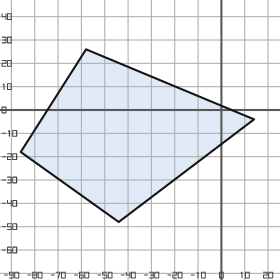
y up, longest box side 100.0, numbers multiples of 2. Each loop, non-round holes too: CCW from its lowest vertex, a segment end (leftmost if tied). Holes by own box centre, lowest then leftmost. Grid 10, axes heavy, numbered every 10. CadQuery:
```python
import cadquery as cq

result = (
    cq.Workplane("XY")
    .moveTo(-44.0, -48.0)
    .lineTo(14.0, -4.0)
    .lineTo(-58.0, 26.0)
    .lineTo(-86.0, -18.0)
    .close()
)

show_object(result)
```